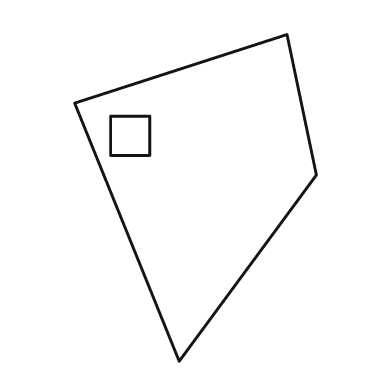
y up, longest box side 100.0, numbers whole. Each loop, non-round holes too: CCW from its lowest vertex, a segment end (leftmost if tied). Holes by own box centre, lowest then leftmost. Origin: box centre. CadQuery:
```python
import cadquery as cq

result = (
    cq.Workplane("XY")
    .moveTo(-5.0, -50.0)
    .lineTo(37.0, 7.0)
    .lineTo(28.0, 50.0)
    .lineTo(-37.0, 29.0)
    .close()
    .moveTo(-26.0, 13.0)
    .lineTo(-14.0, 13.0)
    .lineTo(-14.0, 25.0)
    .lineTo(-26.0, 25.0)
    .close()
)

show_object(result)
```